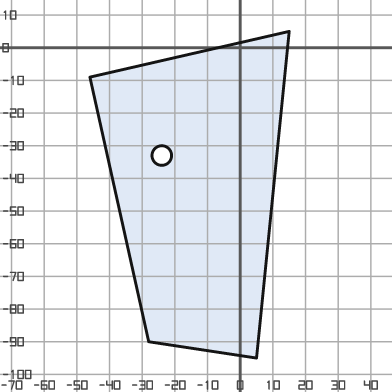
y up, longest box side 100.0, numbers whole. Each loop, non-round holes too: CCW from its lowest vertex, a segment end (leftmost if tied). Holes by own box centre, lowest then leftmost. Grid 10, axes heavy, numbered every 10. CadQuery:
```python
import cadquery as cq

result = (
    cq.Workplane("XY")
    .moveTo(5.0, -95.0)
    .lineTo(15.0, 5.0)
    .lineTo(-46.0, -9.0)
    .lineTo(-28.0, -90.0)
    .close()
    .moveTo(-24.0, -33.0)
    .circle(3.0)
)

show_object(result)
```